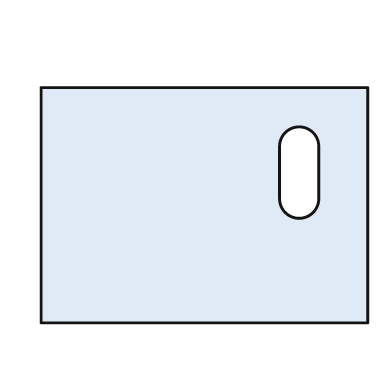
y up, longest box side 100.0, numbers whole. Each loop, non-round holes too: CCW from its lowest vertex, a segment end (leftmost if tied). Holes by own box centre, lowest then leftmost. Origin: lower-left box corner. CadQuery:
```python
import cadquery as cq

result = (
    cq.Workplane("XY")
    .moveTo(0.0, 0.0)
    .lineTo(100.0, 0.0)
    .lineTo(100.0, 72.0)
    .lineTo(0.0, 72.0)
    .close()
    .moveTo(73.0, 38.0)
    .threePointArc((79.0, 32.0), (85.0, 38.0))
    .lineTo(85.0, 54.0)
    .threePointArc((79.0, 60.0), (73.0, 54.0))
    .close()
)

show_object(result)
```